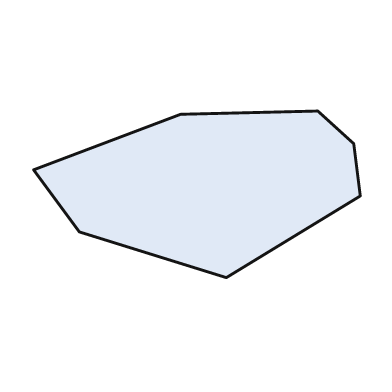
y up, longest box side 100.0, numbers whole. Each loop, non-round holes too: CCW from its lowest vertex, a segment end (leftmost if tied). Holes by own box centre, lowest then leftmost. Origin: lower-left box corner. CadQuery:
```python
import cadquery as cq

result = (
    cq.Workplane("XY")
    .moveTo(59.0, 0.0)
    .lineTo(100.0, 25.0)
    .lineTo(98.0, 41.0)
    .lineTo(87.0, 51.0)
    .lineTo(45.0, 50.0)
    .lineTo(0.0, 33.0)
    .lineTo(14.0, 14.0)
    .close()
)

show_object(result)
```